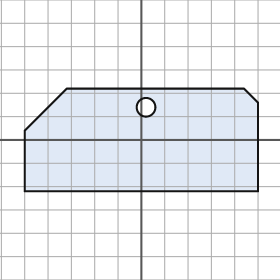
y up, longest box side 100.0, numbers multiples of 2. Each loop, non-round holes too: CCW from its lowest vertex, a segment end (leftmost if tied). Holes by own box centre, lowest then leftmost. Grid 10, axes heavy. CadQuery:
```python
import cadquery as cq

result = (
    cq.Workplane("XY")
    .moveTo(-50.0, -22.0)
    .lineTo(50.0, -22.0)
    .lineTo(50.0, 16.0)
    .lineTo(44.0, 22.0)
    .lineTo(-32.0, 22.0)
    .lineTo(-50.0, 4.0)
    .close()
    .moveTo(2.0, 14.0)
    .circle(4.0)
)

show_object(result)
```